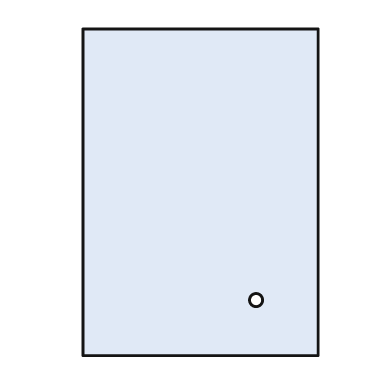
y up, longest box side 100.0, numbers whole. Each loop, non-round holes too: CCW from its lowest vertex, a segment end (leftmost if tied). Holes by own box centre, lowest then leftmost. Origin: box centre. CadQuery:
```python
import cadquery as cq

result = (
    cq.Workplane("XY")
    .moveTo(-36.0, -50.0)
    .lineTo(36.0, -50.0)
    .lineTo(36.0, 50.0)
    .lineTo(-36.0, 50.0)
    .close()
    .moveTo(17.0, -33.0)
    .circle(2.0)
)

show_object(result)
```